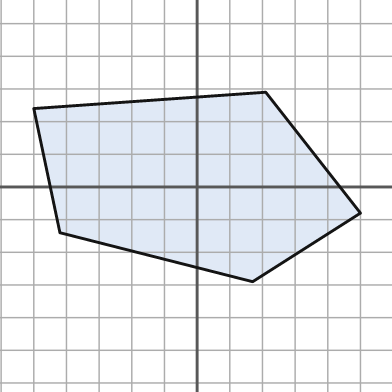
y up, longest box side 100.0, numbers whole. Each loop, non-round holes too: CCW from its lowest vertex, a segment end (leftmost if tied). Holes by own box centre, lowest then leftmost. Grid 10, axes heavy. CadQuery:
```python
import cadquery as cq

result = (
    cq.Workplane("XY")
    .moveTo(17.0, -29.0)
    .lineTo(50.0, -8.0)
    .lineTo(21.0, 29.0)
    .lineTo(-50.0, 24.0)
    .lineTo(-42.0, -14.0)
    .close()
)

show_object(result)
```